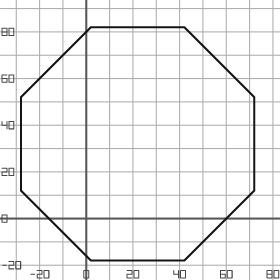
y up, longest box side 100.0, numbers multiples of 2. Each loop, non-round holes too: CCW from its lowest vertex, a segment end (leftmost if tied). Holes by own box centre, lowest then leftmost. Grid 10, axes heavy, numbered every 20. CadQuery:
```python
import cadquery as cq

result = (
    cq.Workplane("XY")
    .moveTo(2.0, -18.0)
    .lineTo(42.0, -18.0)
    .lineTo(72.0, 12.0)
    .lineTo(72.0, 52.0)
    .lineTo(42.0, 82.0)
    .lineTo(2.0, 82.0)
    .lineTo(-28.0, 52.0)
    .lineTo(-28.0, 12.0)
    .close()
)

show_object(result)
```